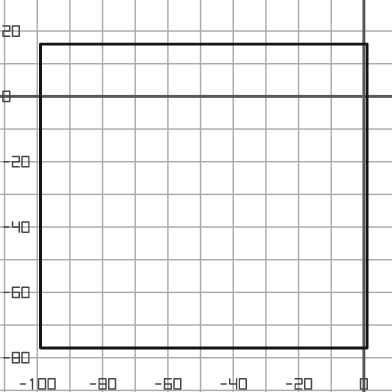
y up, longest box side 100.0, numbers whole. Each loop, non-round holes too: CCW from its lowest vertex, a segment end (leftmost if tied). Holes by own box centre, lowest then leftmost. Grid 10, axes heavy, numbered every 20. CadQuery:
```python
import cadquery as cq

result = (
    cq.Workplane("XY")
    .moveTo(-99.0, -77.0)
    .lineTo(1.0, -77.0)
    .lineTo(1.0, 16.0)
    .lineTo(-99.0, 16.0)
    .close()
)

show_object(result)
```